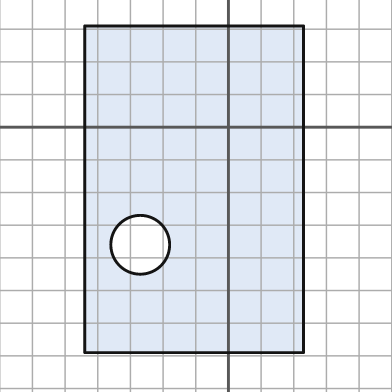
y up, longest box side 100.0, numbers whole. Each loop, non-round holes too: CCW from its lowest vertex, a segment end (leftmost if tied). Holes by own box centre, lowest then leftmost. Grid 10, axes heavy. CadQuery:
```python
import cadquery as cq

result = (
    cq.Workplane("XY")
    .moveTo(-44.0, -69.0)
    .lineTo(23.0, -69.0)
    .lineTo(23.0, 31.0)
    .lineTo(-44.0, 31.0)
    .close()
    .moveTo(-27.0, -36.0)
    .circle(9.0)
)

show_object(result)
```